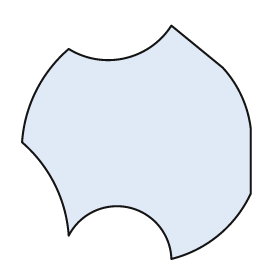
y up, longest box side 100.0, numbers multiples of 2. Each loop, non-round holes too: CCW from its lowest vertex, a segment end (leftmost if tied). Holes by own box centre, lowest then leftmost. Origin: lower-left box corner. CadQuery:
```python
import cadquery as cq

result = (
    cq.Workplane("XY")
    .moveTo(64.0, 0.0)
    .threePointArc((84.0, 10.0), (98.0, 28.0))
    .lineTo(98.0, 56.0)
    .threePointArc((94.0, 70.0), (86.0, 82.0))
    .lineTo(64.0, 100.0)
    .threePointArc((44.0, 86.0), (20.0, 90.0))
    .threePointArc((6.0, 72.0), (0.0, 50.0))
    .threePointArc((14.0, 32.0), (20.0, 10.0))
    .threePointArc((46.0, 22.0), (64.0, 0.0))
    .close()
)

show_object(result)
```